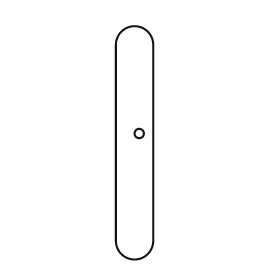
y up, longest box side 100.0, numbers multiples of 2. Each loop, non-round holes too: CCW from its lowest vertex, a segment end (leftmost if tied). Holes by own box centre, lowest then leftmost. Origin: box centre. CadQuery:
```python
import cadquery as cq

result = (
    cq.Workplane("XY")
    .moveTo(-8.0, -42.0)
    .threePointArc((0.0, -50.0), (8.0, -42.0))
    .lineTo(8.0, 42.0)
    .threePointArc((0.0, 50.0), (-8.0, 42.0))
    .close()
    .moveTo(2.0, 4.0)
    .circle(2.0)
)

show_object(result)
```